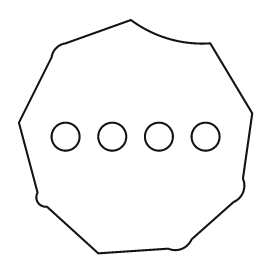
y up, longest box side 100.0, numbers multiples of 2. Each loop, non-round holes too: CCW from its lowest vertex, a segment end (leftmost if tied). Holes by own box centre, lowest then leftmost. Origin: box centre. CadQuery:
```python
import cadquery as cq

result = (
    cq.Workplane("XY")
    .moveTo(-16.0, -50.0)
    .lineTo(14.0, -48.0)
    .threePointArc((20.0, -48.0), (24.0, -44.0))
    .lineTo(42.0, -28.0)
    .threePointArc((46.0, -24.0), (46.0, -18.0))
    .lineTo(50.0, 10.0)
    .lineTo(32.0, 40.0)
    .threePointArc((14.0, 42.0), (-2.0, 50.0))
    .lineTo(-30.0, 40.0)
    .threePointArc((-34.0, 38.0), (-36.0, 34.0))
    .lineTo(-50.0, 6.0)
    .lineTo(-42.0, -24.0)
    .threePointArc((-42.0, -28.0), (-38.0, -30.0))
    .close()
    .moveTo(-30.0, 0.0)
    .circle(6.0)
    .moveTo(-10.0, 0.0)
    .circle(6.0)
    .moveTo(10.0, 0.0)
    .circle(6.0)
    .moveTo(30.0, 0.0)
    .circle(6.0)
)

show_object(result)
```